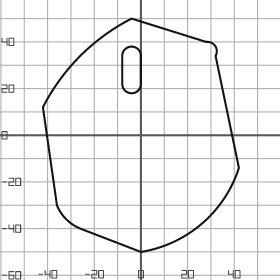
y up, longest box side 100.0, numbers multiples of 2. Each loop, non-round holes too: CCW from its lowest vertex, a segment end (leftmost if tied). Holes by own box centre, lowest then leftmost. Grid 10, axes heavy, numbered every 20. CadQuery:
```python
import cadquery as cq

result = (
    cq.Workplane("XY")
    .moveTo(0.0, -50.0)
    .threePointArc((26.0, -38.0), (42.0, -14.0))
    .lineTo(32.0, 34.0)
    .threePointArc((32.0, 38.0), (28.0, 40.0))
    .lineTo(-4.0, 50.0)
    .threePointArc((-26.0, 34.0), (-42.0, 12.0))
    .lineTo(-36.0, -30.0)
    .threePointArc((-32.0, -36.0), (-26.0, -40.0))
    .close()
    .moveTo(-8.0, 22.0)
    .threePointArc((-4.0, 18.0), (0.0, 22.0))
    .lineTo(0.0, 34.0)
    .threePointArc((-4.0, 38.0), (-8.0, 34.0))
    .close()
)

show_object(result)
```